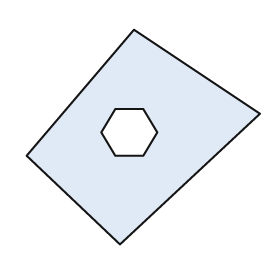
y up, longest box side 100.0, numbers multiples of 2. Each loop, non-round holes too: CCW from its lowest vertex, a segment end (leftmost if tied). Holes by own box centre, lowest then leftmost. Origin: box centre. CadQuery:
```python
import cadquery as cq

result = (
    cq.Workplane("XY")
    .moveTo(-10.0, -46.0)
    .lineTo(50.0, 10.0)
    .lineTo(-4.0, 46.0)
    .lineTo(-50.0, -8.0)
    .close()
    .moveTo(-12.0, -8.0)
    .lineTo(0.0, -8.0)
    .lineTo(6.0, 2.0)
    .lineTo(0.0, 12.0)
    .lineTo(-12.0, 12.0)
    .lineTo(-18.0, 2.0)
    .close()
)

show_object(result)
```